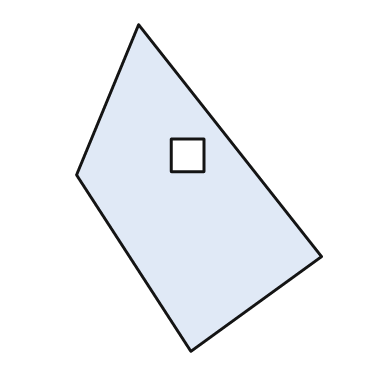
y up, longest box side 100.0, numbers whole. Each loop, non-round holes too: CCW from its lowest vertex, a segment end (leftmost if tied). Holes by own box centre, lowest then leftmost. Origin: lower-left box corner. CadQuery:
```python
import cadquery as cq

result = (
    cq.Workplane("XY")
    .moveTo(35.0, 0.0)
    .lineTo(75.0, 29.0)
    .lineTo(19.0, 100.0)
    .lineTo(0.0, 54.0)
    .close()
    .moveTo(29.0, 55.0)
    .lineTo(39.0, 55.0)
    .lineTo(39.0, 65.0)
    .lineTo(29.0, 65.0)
    .close()
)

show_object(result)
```